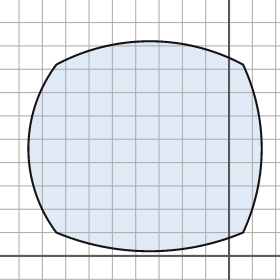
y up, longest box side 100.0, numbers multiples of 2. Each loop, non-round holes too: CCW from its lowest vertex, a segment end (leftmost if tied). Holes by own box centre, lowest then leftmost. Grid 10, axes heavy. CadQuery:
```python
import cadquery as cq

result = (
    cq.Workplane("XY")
    .moveTo(-74.0, 10.0)
    .threePointArc((-34.0, 2.0), (6.0, 10.0))
    .threePointArc((14.0, 46.0), (6.0, 82.0))
    .threePointArc((-34.0, 92.0), (-74.0, 82.0))
    .threePointArc((-86.0, 46.0), (-74.0, 10.0))
    .close()
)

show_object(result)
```